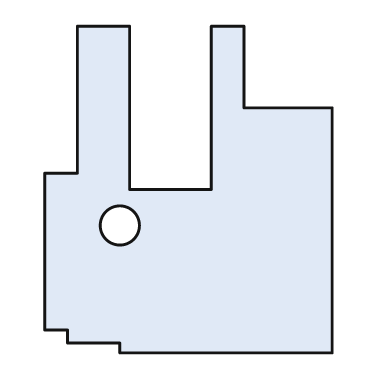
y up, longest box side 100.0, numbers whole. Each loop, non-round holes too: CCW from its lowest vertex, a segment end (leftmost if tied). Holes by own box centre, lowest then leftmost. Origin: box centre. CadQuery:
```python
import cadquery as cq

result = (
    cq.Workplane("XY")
    .moveTo(-21.0, -50.0)
    .lineTo(44.0, -50.0)
    .lineTo(44.0, 25.0)
    .lineTo(17.0, 25.0)
    .lineTo(17.0, 50.0)
    .lineTo(7.0, 50.0)
    .lineTo(7.0, 0.0)
    .lineTo(-18.0, 0.0)
    .lineTo(-18.0, 50.0)
    .lineTo(-34.0, 50.0)
    .lineTo(-34.0, 5.0)
    .lineTo(-44.0, 5.0)
    .lineTo(-44.0, -43.0)
    .lineTo(-37.0, -43.0)
    .lineTo(-37.0, -47.0)
    .lineTo(-21.0, -47.0)
    .close()
    .moveTo(-21.0, -11.0)
    .circle(6.0)
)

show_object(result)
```